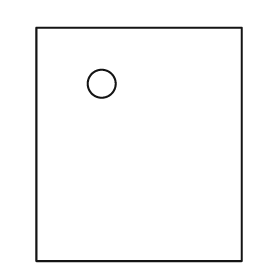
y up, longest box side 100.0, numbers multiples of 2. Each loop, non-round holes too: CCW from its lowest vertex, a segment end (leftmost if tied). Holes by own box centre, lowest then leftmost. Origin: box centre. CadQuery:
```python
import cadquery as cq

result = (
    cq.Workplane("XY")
    .moveTo(-44.0, -50.0)
    .lineTo(44.0, -50.0)
    .lineTo(44.0, 50.0)
    .lineTo(-44.0, 50.0)
    .close()
    .moveTo(-16.0, 26.0)
    .circle(6.0)
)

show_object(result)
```